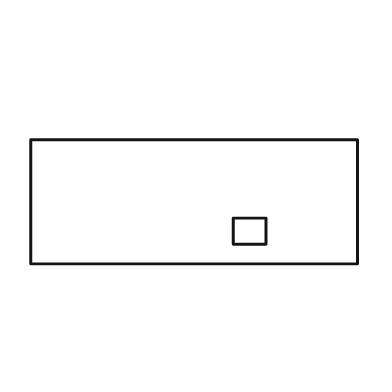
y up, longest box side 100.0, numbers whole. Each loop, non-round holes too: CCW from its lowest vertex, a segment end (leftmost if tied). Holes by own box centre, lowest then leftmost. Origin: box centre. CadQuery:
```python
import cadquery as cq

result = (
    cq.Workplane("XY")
    .moveTo(-50.0, -19.0)
    .lineTo(50.0, -19.0)
    .lineTo(50.0, 19.0)
    .lineTo(-50.0, 19.0)
    .close()
    .moveTo(12.0, -13.0)
    .lineTo(22.0, -13.0)
    .lineTo(22.0, -5.0)
    .lineTo(12.0, -5.0)
    .close()
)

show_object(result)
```